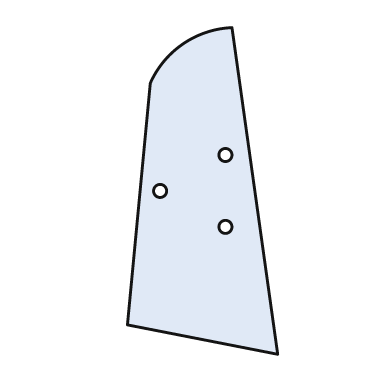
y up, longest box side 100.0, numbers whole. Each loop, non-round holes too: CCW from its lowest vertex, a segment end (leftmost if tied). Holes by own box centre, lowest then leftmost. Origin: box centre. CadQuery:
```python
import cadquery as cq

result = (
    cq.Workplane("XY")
    .moveTo(23.0, -50.0)
    .lineTo(9.0, 50.0)
    .threePointArc((-6.0, 45.0), (-16.0, 33.0))
    .lineTo(-23.0, -41.0)
    .close()
    .moveTo(7.0, -11.0)
    .circle(2.0)
    .moveTo(-13.0, 0.0)
    .circle(2.0)
    .moveTo(7.0, 11.0)
    .circle(2.0)
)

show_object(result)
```